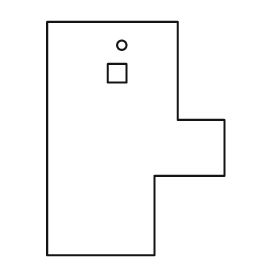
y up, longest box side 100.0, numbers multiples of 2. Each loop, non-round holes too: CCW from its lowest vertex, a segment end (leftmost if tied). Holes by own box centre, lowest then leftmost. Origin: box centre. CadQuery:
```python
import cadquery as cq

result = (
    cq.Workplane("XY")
    .moveTo(-38.0, -50.0)
    .lineTo(8.0, -50.0)
    .lineTo(8.0, -16.0)
    .lineTo(38.0, -16.0)
    .lineTo(38.0, 8.0)
    .lineTo(18.0, 8.0)
    .lineTo(18.0, 50.0)
    .lineTo(-38.0, 50.0)
    .close()
    .moveTo(-12.0, 24.0)
    .lineTo(-4.0, 24.0)
    .lineTo(-4.0, 32.0)
    .lineTo(-12.0, 32.0)
    .close()
    .moveTo(-6.0, 40.0)
    .circle(2.0)
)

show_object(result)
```